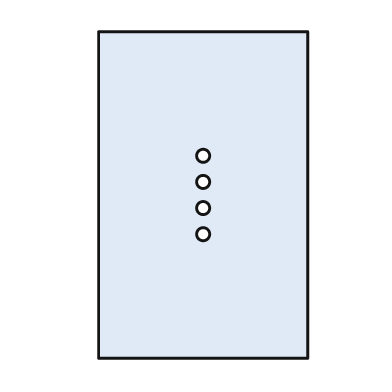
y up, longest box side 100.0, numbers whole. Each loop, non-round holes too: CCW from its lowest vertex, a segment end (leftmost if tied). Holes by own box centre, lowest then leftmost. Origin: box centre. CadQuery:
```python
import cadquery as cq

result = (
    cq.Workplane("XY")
    .moveTo(-32.0, -50.0)
    .lineTo(32.0, -50.0)
    .lineTo(32.0, 50.0)
    .lineTo(-32.0, 50.0)
    .close()
    .moveTo(0.0, -12.0)
    .circle(2.0)
    .moveTo(0.0, -4.0)
    .circle(2.0)
    .moveTo(0.0, 4.0)
    .circle(2.0)
    .moveTo(0.0, 12.0)
    .circle(2.0)
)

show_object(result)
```